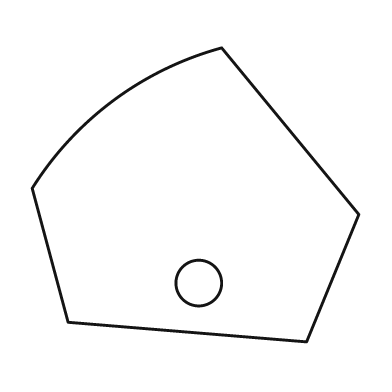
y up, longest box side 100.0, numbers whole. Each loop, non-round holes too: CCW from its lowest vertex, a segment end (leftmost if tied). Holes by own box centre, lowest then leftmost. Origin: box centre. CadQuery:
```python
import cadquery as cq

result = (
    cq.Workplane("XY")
    .moveTo(34.0, -45.0)
    .lineTo(50.0, -6.0)
    .lineTo(8.0, 45.0)
    .threePointArc((-25.0, 29.0), (-50.0, 2.0))
    .lineTo(-39.0, -39.0)
    .close()
    .moveTo(1.0, -27.0)
    .circle(7.0)
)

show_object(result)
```